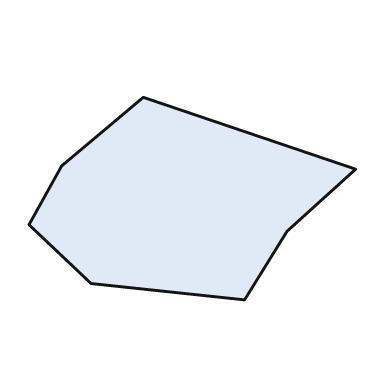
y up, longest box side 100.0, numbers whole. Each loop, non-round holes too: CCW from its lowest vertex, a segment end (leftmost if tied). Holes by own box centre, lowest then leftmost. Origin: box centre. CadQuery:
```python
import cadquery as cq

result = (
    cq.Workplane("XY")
    .moveTo(16.0, -31.0)
    .lineTo(29.0, -10.0)
    .lineTo(50.0, 9.0)
    .lineTo(-15.0, 31.0)
    .lineTo(-40.0, 10.0)
    .lineTo(-50.0, -8.0)
    .lineTo(-31.0, -26.0)
    .close()
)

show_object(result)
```